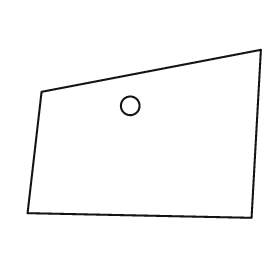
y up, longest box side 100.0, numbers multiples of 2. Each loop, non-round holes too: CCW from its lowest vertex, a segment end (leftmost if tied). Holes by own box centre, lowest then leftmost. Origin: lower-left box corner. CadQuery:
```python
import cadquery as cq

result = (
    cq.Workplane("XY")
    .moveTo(96.0, 0.0)
    .lineTo(100.0, 72.0)
    .lineTo(6.0, 54.0)
    .lineTo(0.0, 2.0)
    .close()
    .moveTo(44.0, 48.0)
    .circle(4.0)
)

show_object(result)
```